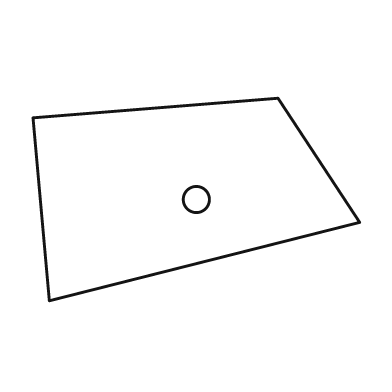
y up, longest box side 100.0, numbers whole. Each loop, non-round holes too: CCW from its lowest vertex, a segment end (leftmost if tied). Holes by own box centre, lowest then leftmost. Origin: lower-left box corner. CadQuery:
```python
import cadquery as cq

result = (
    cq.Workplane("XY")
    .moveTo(5.0, 0.0)
    .lineTo(100.0, 24.0)
    .lineTo(75.0, 62.0)
    .lineTo(0.0, 56.0)
    .close()
    .moveTo(50.0, 31.0)
    .circle(4.0)
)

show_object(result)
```